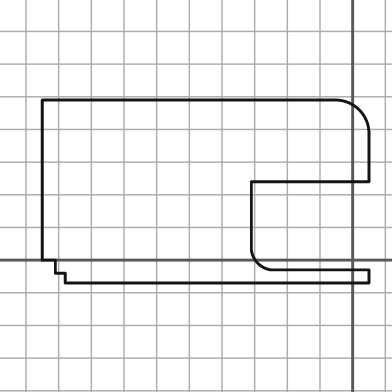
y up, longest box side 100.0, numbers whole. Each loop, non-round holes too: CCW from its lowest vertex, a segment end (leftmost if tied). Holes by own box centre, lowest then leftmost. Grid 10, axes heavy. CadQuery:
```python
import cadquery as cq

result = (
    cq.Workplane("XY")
    .moveTo(-88.0, -7.0)
    .lineTo(5.0, -7.0)
    .lineTo(5.0, -3.0)
    .lineTo(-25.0, -3.0)
    .threePointArc((-29.0, -1.0), (-31.0, 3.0))
    .lineTo(-31.0, 24.0)
    .lineTo(5.0, 24.0)
    .lineTo(5.0, 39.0)
    .threePointArc((2.0, 46.0), (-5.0, 49.0))
    .lineTo(-95.0, 49.0)
    .lineTo(-95.0, 0.0)
    .lineTo(-91.0, 0.0)
    .lineTo(-91.0, -4.0)
    .lineTo(-88.0, -4.0)
    .close()
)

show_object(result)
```